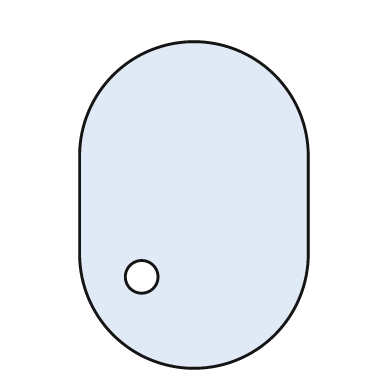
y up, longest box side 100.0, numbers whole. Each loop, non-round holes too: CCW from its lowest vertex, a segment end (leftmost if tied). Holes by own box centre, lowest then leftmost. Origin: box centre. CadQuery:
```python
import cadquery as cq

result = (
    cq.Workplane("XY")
    .moveTo(-35.0, -15.0)
    .threePointArc((0.0, -50.0), (35.0, -15.0))
    .lineTo(35.0, 15.0)
    .threePointArc((0.0, 50.0), (-35.0, 15.0))
    .close()
    .moveTo(-16.0, -22.0)
    .circle(5.0)
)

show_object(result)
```